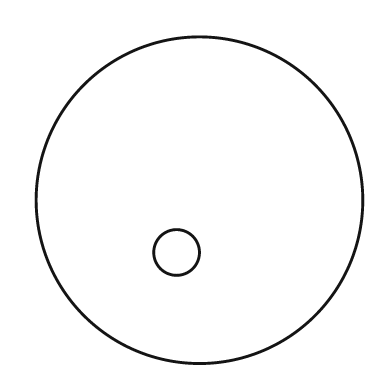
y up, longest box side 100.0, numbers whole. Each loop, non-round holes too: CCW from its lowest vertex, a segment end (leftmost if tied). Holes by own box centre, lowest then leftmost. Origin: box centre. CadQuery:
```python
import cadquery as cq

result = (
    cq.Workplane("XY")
    .moveTo(0.0, 0.0)
    .circle(50.0)
    .moveTo(-7.0, -16.0)
    .circle(7.0)
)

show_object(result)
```